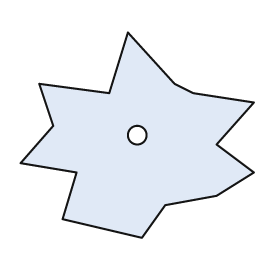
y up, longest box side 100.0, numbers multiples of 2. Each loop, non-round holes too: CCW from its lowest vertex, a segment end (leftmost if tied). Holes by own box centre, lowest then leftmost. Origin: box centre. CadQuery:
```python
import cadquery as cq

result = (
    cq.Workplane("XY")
    .moveTo(2.0, -44.0)
    .lineTo(12.0, -30.0)
    .lineTo(34.0, -26.0)
    .lineTo(50.0, -16.0)
    .lineTo(34.0, -4.0)
    .lineTo(50.0, 14.0)
    .lineTo(24.0, 18.0)
    .lineTo(16.0, 22.0)
    .lineTo(-4.0, 44.0)
    .lineTo(-12.0, 18.0)
    .lineTo(-42.0, 22.0)
    .lineTo(-36.0, 4.0)
    .lineTo(-50.0, -12.0)
    .lineTo(-26.0, -16.0)
    .lineTo(-32.0, -36.0)
    .close()
    .moveTo(0.0, 0.0)
    .circle(4.0)
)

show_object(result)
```